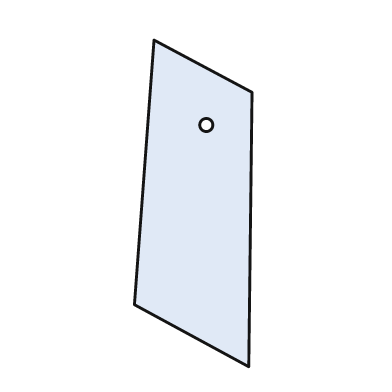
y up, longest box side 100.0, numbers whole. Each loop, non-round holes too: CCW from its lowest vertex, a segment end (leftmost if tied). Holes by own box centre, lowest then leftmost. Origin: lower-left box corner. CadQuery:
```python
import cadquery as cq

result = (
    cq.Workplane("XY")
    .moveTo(35.0, 0.0)
    .lineTo(36.0, 84.0)
    .lineTo(6.0, 100.0)
    .lineTo(0.0, 19.0)
    .close()
    .moveTo(22.0, 74.0)
    .circle(2.0)
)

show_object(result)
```